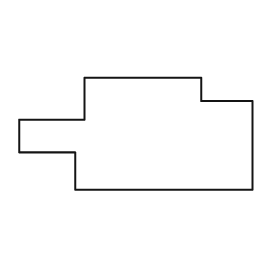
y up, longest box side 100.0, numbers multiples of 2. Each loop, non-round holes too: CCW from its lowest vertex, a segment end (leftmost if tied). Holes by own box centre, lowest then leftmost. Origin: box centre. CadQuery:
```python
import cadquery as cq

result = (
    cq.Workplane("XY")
    .moveTo(-26.0, -24.0)
    .lineTo(50.0, -24.0)
    .lineTo(50.0, 14.0)
    .lineTo(28.0, 14.0)
    .lineTo(28.0, 24.0)
    .lineTo(-22.0, 24.0)
    .lineTo(-22.0, 6.0)
    .lineTo(-50.0, 6.0)
    .lineTo(-50.0, -8.0)
    .lineTo(-26.0, -8.0)
    .close()
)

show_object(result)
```